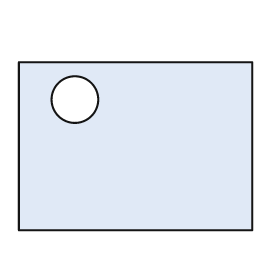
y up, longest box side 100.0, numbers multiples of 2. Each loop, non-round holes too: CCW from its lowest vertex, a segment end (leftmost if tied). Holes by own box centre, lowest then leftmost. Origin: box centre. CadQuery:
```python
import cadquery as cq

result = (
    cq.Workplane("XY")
    .moveTo(-50.0, -36.0)
    .lineTo(50.0, -36.0)
    .lineTo(50.0, 36.0)
    .lineTo(-50.0, 36.0)
    .close()
    .moveTo(-26.0, 20.0)
    .circle(10.0)
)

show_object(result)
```